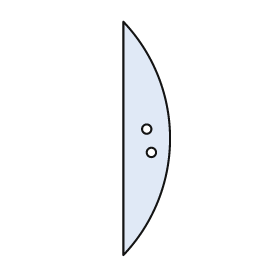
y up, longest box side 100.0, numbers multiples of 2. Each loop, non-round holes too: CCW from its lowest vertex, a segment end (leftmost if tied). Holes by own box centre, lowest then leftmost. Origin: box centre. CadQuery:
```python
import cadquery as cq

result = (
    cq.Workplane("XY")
    .moveTo(-10.0, -50.0)
    .threePointArc((10.0, 0.0), (-10.0, 50.0))
    .close()
    .moveTo(2.0, -6.0)
    .circle(2.0)
    .moveTo(0.0, 4.0)
    .circle(2.0)
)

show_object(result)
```